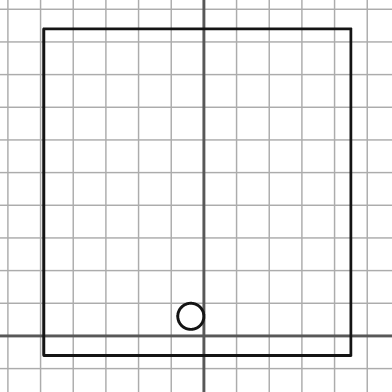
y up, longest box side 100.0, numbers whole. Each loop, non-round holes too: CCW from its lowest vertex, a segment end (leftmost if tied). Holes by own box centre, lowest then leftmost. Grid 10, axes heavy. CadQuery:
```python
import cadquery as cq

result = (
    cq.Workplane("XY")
    .moveTo(-49.0, -6.0)
    .lineTo(45.0, -6.0)
    .lineTo(45.0, 94.0)
    .lineTo(-49.0, 94.0)
    .close()
    .moveTo(-4.0, 6.0)
    .circle(4.0)
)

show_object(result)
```